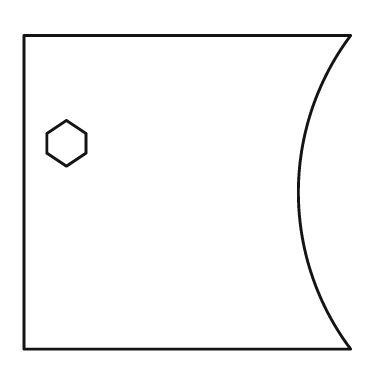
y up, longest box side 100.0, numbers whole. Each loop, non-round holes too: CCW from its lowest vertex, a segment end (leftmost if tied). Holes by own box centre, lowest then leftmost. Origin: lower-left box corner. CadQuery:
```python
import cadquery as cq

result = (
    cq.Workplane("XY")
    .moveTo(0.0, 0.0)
    .lineTo(100.0, 0.0)
    .threePointArc((84.0, 48.0), (100.0, 96.0))
    .lineTo(0.0, 96.0)
    .close()
    .moveTo(13.0, 56.0)
    .lineTo(19.0, 60.0)
    .lineTo(19.0, 66.0)
    .lineTo(13.0, 70.0)
    .lineTo(7.0, 66.0)
    .lineTo(7.0, 60.0)
    .close()
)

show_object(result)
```